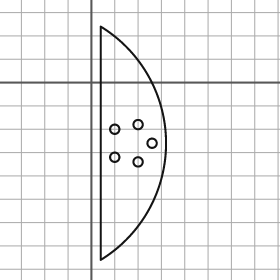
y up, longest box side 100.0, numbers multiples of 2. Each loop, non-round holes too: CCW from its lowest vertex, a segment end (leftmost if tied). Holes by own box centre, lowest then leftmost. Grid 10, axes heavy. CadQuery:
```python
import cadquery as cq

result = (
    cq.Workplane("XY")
    .moveTo(4.0, -76.0)
    .threePointArc((32.0, -26.0), (4.0, 24.0))
    .close()
    .moveTo(20.0, -34.0)
    .circle(2.0)
    .moveTo(10.0, -32.0)
    .circle(2.0)
    .moveTo(26.0, -26.0)
    .circle(2.0)
    .moveTo(10.0, -20.0)
    .circle(2.0)
    .moveTo(20.0, -18.0)
    .circle(2.0)
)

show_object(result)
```